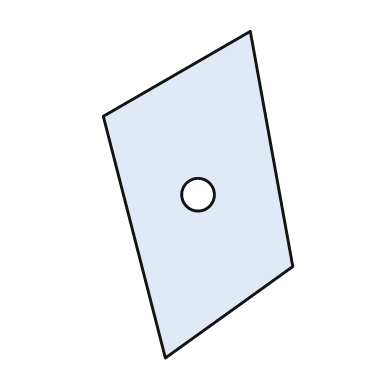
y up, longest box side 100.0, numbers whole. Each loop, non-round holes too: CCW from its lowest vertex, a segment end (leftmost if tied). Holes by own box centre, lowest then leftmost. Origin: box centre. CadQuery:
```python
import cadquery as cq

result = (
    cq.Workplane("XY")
    .moveTo(-10.0, -50.0)
    .lineTo(29.0, -22.0)
    .lineTo(16.0, 50.0)
    .lineTo(-29.0, 24.0)
    .close()
    .moveTo(0.0, 0.0)
    .circle(5.0)
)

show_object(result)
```